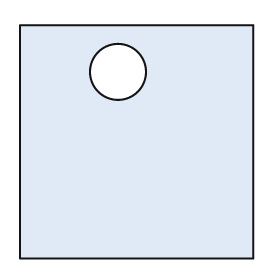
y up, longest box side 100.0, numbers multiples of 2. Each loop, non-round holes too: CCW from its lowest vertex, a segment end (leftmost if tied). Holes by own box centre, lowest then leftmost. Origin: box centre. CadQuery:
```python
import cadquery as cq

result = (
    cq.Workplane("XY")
    .moveTo(-50.0, -50.0)
    .lineTo(50.0, -50.0)
    .lineTo(50.0, 50.0)
    .lineTo(-50.0, 50.0)
    .close()
    .moveTo(-8.0, 30.0)
    .circle(12.0)
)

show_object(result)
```